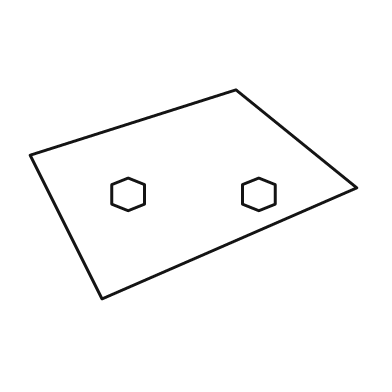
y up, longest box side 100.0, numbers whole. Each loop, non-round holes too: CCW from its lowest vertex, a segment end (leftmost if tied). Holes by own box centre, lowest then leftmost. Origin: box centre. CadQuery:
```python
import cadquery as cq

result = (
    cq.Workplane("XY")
    .moveTo(-28.0, -32.0)
    .lineTo(50.0, 2.0)
    .lineTo(13.0, 32.0)
    .lineTo(-50.0, 12.0)
    .close()
    .moveTo(-20.0, -5.0)
    .lineTo(-15.0, -3.0)
    .lineTo(-15.0, 3.0)
    .lineTo(-20.0, 5.0)
    .lineTo(-25.0, 3.0)
    .lineTo(-25.0, -3.0)
    .close()
    .moveTo(20.0, -5.0)
    .lineTo(25.0, -3.0)
    .lineTo(25.0, 3.0)
    .lineTo(20.0, 5.0)
    .lineTo(15.0, 3.0)
    .lineTo(15.0, -3.0)
    .close()
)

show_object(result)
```